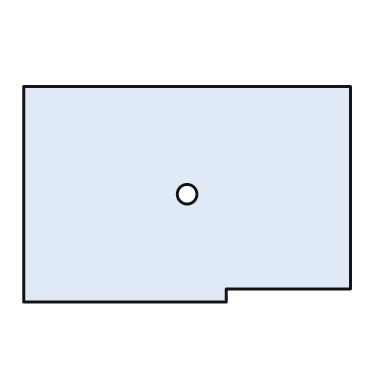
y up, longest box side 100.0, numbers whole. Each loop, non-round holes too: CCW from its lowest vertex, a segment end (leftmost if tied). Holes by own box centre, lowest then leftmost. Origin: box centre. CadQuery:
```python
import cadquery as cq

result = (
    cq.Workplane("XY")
    .moveTo(-50.0, -33.0)
    .lineTo(12.0, -33.0)
    .lineTo(12.0, -29.0)
    .lineTo(50.0, -29.0)
    .lineTo(50.0, 33.0)
    .lineTo(-50.0, 33.0)
    .close()
    .moveTo(0.0, 0.0)
    .circle(3.0)
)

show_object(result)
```